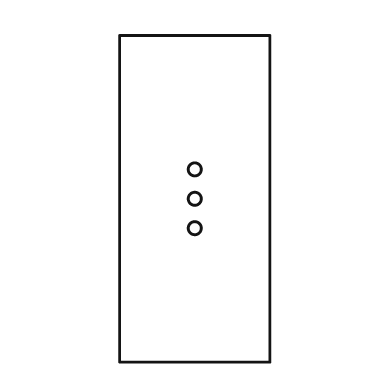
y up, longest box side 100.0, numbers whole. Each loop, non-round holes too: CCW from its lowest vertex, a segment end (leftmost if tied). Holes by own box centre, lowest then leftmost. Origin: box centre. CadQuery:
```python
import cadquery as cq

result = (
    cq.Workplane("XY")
    .moveTo(-23.0, -50.0)
    .lineTo(23.0, -50.0)
    .lineTo(23.0, 50.0)
    .lineTo(-23.0, 50.0)
    .close()
    .moveTo(0.0, -9.0)
    .circle(2.0)
    .moveTo(0.0, 0.0)
    .circle(2.0)
    .moveTo(0.0, 9.0)
    .circle(2.0)
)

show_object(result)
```